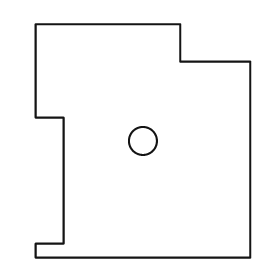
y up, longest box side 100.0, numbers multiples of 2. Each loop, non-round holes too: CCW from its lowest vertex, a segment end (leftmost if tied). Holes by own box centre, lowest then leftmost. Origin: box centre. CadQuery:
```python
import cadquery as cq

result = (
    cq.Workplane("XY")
    .moveTo(-46.0, -50.0)
    .lineTo(46.0, -50.0)
    .lineTo(46.0, 34.0)
    .lineTo(16.0, 34.0)
    .lineTo(16.0, 50.0)
    .lineTo(-46.0, 50.0)
    .lineTo(-46.0, 10.0)
    .lineTo(-34.0, 10.0)
    .lineTo(-34.0, -44.0)
    .lineTo(-46.0, -44.0)
    .close()
    .moveTo(0.0, 0.0)
    .circle(6.0)
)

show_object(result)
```